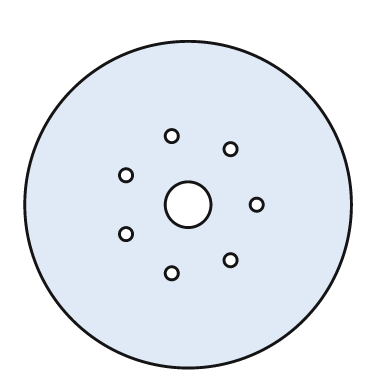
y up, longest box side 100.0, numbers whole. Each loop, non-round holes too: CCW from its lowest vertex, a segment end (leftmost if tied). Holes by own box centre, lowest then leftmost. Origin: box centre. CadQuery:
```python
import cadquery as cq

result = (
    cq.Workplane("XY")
    .moveTo(0.0, 0.0)
    .circle(50.0)
    .moveTo(-5.0, -21.0)
    .circle(2.0)
    .moveTo(13.0, -17.0)
    .circle(2.0)
    .moveTo(-19.0, -9.0)
    .circle(2.0)
    .moveTo(0.0, 0.0)
    .circle(7.0)
    .moveTo(21.0, 0.0)
    .circle(2.0)
    .moveTo(-19.0, 9.0)
    .circle(2.0)
    .moveTo(13.0, 17.0)
    .circle(2.0)
    .moveTo(-5.0, 21.0)
    .circle(2.0)
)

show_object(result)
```